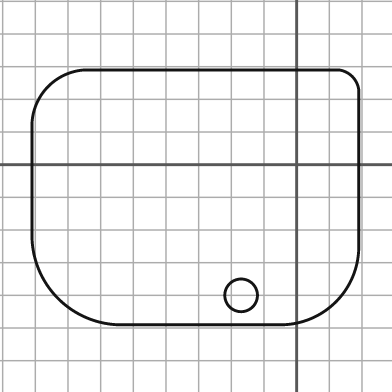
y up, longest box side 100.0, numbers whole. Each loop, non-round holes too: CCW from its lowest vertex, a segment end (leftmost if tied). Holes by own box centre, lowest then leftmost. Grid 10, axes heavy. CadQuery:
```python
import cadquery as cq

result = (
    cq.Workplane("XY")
    .moveTo(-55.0, -49.0)
    .lineTo(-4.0, -49.0)
    .threePointArc((12.0, -42.0), (19.0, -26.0))
    .lineTo(19.0, 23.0)
    .threePointArc((17.0, 27.0), (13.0, 29.0))
    .lineTo(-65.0, 29.0)
    .threePointArc((-76.0, 24.0), (-81.0, 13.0))
    .lineTo(-81.0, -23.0)
    .threePointArc((-73.0, -41.0), (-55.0, -49.0))
    .close()
    .moveTo(-17.0, -40.0)
    .circle(5.0)
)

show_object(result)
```